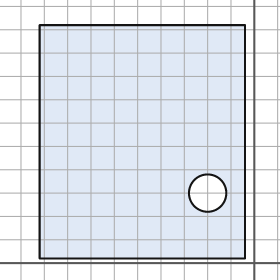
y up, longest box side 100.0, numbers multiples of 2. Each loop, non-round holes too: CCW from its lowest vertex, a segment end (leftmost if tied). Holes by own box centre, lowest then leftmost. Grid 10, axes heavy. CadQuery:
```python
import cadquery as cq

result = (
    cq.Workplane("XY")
    .moveTo(-92.0, 2.0)
    .lineTo(-4.0, 2.0)
    .lineTo(-4.0, 102.0)
    .lineTo(-92.0, 102.0)
    .close()
    .moveTo(-20.0, 30.0)
    .circle(8.0)
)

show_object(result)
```